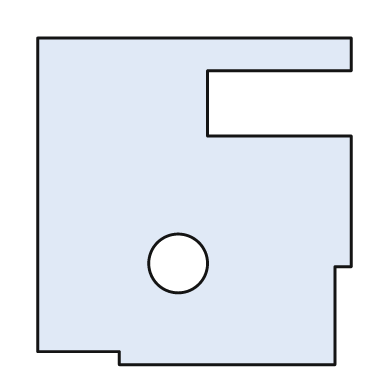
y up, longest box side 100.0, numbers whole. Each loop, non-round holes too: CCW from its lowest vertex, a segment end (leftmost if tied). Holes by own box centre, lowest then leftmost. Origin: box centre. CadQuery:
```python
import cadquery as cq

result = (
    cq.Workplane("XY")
    .moveTo(-23.0, -50.0)
    .lineTo(43.0, -50.0)
    .lineTo(43.0, -20.0)
    .lineTo(48.0, -20.0)
    .lineTo(48.0, 20.0)
    .lineTo(4.0, 20.0)
    .lineTo(4.0, 40.0)
    .lineTo(48.0, 40.0)
    .lineTo(48.0, 50.0)
    .lineTo(-48.0, 50.0)
    .lineTo(-48.0, -46.0)
    .lineTo(-23.0, -46.0)
    .close()
    .moveTo(-5.0, -19.0)
    .circle(9.0)
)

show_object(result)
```